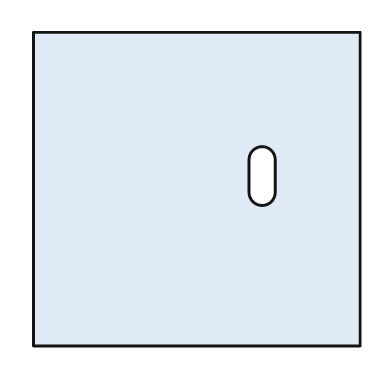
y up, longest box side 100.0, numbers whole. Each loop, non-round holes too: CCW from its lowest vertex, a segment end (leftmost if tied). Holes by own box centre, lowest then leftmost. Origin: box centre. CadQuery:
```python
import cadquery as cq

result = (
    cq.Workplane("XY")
    .moveTo(-50.0, -48.0)
    .lineTo(50.0, -48.0)
    .lineTo(50.0, 48.0)
    .lineTo(-50.0, 48.0)
    .close()
    .moveTo(16.0, -1.0)
    .threePointArc((20.0, -5.0), (24.0, -1.0))
    .lineTo(24.0, 9.0)
    .threePointArc((20.0, 13.0), (16.0, 9.0))
    .close()
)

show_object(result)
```